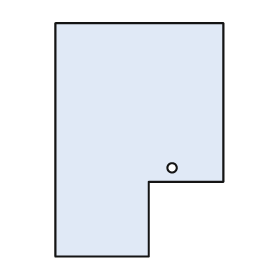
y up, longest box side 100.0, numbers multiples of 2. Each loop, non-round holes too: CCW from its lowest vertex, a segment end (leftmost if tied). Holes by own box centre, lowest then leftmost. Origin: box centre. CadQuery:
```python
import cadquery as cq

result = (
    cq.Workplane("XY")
    .moveTo(-36.0, -50.0)
    .lineTo(4.0, -50.0)
    .lineTo(4.0, -18.0)
    .lineTo(36.0, -18.0)
    .lineTo(36.0, 50.0)
    .lineTo(-36.0, 50.0)
    .close()
    .moveTo(14.0, -12.0)
    .circle(2.0)
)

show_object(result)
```